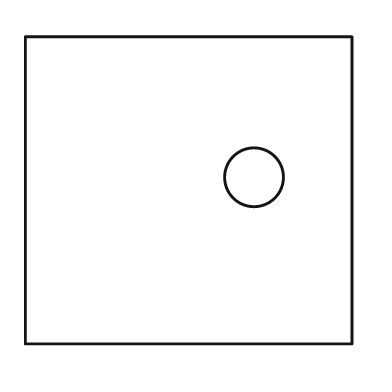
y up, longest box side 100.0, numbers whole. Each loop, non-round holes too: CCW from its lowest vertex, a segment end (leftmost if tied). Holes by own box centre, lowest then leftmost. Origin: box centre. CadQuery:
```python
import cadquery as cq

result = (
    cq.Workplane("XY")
    .moveTo(-50.0, -47.0)
    .lineTo(50.0, -47.0)
    .lineTo(50.0, 47.0)
    .lineTo(-50.0, 47.0)
    .close()
    .moveTo(20.0, 4.0)
    .circle(9.0)
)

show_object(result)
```